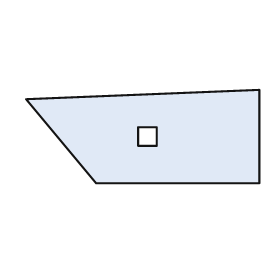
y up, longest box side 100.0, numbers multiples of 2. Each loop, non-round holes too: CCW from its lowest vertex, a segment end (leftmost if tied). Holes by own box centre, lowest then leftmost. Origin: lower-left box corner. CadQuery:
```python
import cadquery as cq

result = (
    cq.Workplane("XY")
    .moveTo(30.0, 0.0)
    .lineTo(100.0, 0.0)
    .lineTo(100.0, 40.0)
    .lineTo(0.0, 36.0)
    .close()
    .moveTo(48.0, 16.0)
    .lineTo(56.0, 16.0)
    .lineTo(56.0, 24.0)
    .lineTo(48.0, 24.0)
    .close()
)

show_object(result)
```